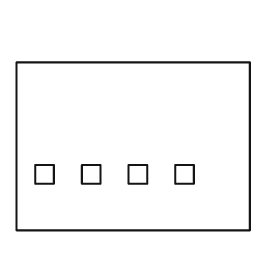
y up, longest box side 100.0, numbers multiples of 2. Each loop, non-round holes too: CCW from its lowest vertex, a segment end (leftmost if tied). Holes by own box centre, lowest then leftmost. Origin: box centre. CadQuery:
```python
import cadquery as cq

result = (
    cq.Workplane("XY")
    .moveTo(-50.0, -36.0)
    .lineTo(50.0, -36.0)
    .lineTo(50.0, 36.0)
    .lineTo(-50.0, 36.0)
    .close()
    .moveTo(-42.0, -16.0)
    .lineTo(-34.0, -16.0)
    .lineTo(-34.0, -8.0)
    .lineTo(-42.0, -8.0)
    .close()
    .moveTo(-22.0, -16.0)
    .lineTo(-14.0, -16.0)
    .lineTo(-14.0, -8.0)
    .lineTo(-22.0, -8.0)
    .close()
    .moveTo(-2.0, -16.0)
    .lineTo(6.0, -16.0)
    .lineTo(6.0, -8.0)
    .lineTo(-2.0, -8.0)
    .close()
    .moveTo(18.0, -16.0)
    .lineTo(26.0, -16.0)
    .lineTo(26.0, -8.0)
    .lineTo(18.0, -8.0)
    .close()
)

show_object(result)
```